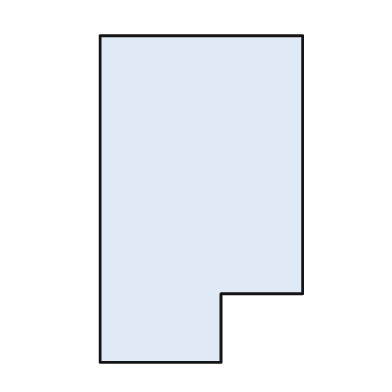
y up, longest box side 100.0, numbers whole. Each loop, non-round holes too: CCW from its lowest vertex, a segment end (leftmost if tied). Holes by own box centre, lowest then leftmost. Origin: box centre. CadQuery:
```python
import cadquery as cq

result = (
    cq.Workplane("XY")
    .moveTo(-31.0, -50.0)
    .lineTo(6.0, -50.0)
    .lineTo(6.0, -29.0)
    .lineTo(31.0, -29.0)
    .lineTo(31.0, 50.0)
    .lineTo(-31.0, 50.0)
    .close()
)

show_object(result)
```